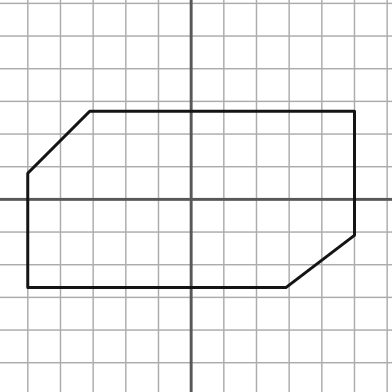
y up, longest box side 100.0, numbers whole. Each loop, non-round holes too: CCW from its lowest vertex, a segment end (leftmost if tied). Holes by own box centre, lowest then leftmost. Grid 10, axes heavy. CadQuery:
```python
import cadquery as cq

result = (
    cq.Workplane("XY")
    .moveTo(-50.0, -27.0)
    .lineTo(29.0, -27.0)
    .lineTo(50.0, -11.0)
    .lineTo(50.0, 27.0)
    .lineTo(-31.0, 27.0)
    .lineTo(-50.0, 8.0)
    .close()
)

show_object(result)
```